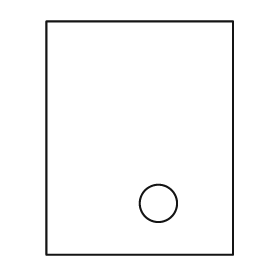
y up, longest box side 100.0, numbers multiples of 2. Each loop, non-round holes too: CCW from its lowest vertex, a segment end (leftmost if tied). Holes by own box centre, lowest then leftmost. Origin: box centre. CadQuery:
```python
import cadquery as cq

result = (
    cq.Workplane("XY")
    .moveTo(-40.0, -50.0)
    .lineTo(40.0, -50.0)
    .lineTo(40.0, 50.0)
    .lineTo(-40.0, 50.0)
    .close()
    .moveTo(8.0, -28.0)
    .circle(8.0)
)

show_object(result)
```